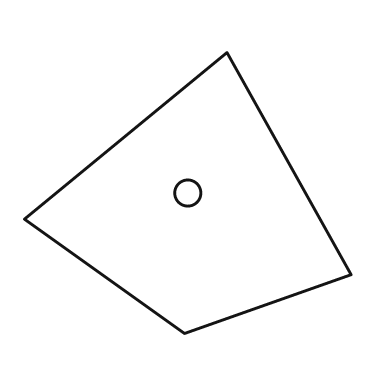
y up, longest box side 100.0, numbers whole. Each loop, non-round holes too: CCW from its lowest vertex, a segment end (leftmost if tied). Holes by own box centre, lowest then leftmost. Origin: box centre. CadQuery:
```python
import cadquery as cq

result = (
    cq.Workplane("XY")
    .moveTo(-1.0, -43.0)
    .lineTo(50.0, -25.0)
    .lineTo(12.0, 43.0)
    .lineTo(-50.0, -8.0)
    .close()
    .moveTo(0.0, 0.0)
    .circle(4.0)
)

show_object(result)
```